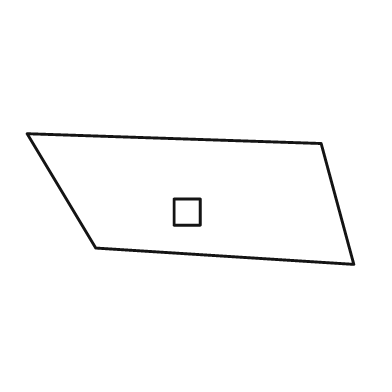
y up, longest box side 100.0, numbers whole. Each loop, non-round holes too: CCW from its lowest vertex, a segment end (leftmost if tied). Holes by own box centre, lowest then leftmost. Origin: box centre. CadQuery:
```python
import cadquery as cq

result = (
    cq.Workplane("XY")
    .moveTo(50.0, -20.0)
    .lineTo(40.0, 17.0)
    .lineTo(-50.0, 20.0)
    .lineTo(-29.0, -15.0)
    .close()
    .moveTo(-5.0, -8.0)
    .lineTo(3.0, -8.0)
    .lineTo(3.0, 0.0)
    .lineTo(-5.0, 0.0)
    .close()
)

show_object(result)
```